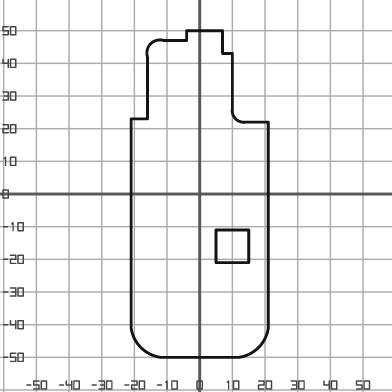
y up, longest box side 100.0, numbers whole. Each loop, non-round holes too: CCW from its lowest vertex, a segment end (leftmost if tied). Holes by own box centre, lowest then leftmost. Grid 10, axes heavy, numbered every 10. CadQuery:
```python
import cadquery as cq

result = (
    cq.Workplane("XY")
    .moveTo(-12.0, -50.0)
    .lineTo(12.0, -50.0)
    .threePointArc((18.0, -47.0), (21.0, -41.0))
    .lineTo(21.0, 22.0)
    .lineTo(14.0, 22.0)
    .threePointArc((11.0, 23.0), (10.0, 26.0))
    .lineTo(10.0, 43.0)
    .lineTo(7.0, 43.0)
    .lineTo(7.0, 50.0)
    .lineTo(-4.0, 50.0)
    .lineTo(-4.0, 47.0)
    .lineTo(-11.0, 47.0)
    .threePointArc((-15.0, 46.0), (-16.0, 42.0))
    .lineTo(-16.0, 23.0)
    .lineTo(-21.0, 23.0)
    .lineTo(-21.0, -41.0)
    .threePointArc((-18.0, -47.0), (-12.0, -50.0))
    .close()
    .moveTo(5.0, -21.0)
    .lineTo(15.0, -21.0)
    .lineTo(15.0, -11.0)
    .lineTo(5.0, -11.0)
    .close()
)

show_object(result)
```